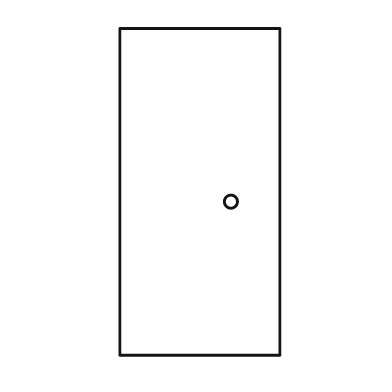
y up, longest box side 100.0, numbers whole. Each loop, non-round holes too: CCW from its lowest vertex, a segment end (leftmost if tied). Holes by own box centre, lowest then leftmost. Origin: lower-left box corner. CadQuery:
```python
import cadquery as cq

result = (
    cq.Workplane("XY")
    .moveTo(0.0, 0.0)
    .lineTo(49.0, 0.0)
    .lineTo(49.0, 100.0)
    .lineTo(0.0, 100.0)
    .close()
    .moveTo(34.0, 47.0)
    .circle(2.0)
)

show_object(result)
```